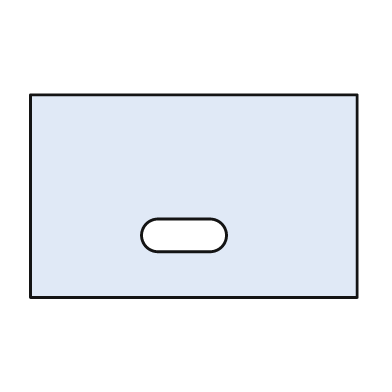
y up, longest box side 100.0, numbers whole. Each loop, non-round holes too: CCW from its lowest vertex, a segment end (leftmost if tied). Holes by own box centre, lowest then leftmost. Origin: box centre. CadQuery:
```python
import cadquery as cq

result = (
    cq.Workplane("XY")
    .moveTo(-50.0, -31.0)
    .lineTo(50.0, -31.0)
    .lineTo(50.0, 31.0)
    .lineTo(-50.0, 31.0)
    .close()
    .moveTo(-11.0, -17.0)
    .lineTo(5.0, -17.0)
    .threePointArc((10.0, -12.0), (5.0, -7.0))
    .lineTo(-11.0, -7.0)
    .threePointArc((-16.0, -12.0), (-11.0, -17.0))
    .close()
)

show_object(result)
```